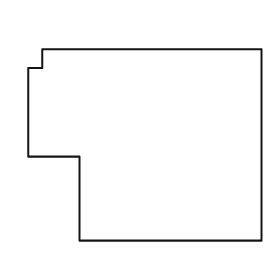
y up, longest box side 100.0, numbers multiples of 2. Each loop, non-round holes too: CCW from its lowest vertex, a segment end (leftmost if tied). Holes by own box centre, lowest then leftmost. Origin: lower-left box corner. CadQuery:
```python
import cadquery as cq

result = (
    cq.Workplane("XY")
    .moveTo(22.0, 0.0)
    .lineTo(100.0, 0.0)
    .lineTo(100.0, 82.0)
    .lineTo(6.0, 82.0)
    .lineTo(6.0, 74.0)
    .lineTo(0.0, 74.0)
    .lineTo(0.0, 36.0)
    .lineTo(22.0, 36.0)
    .close()
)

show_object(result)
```